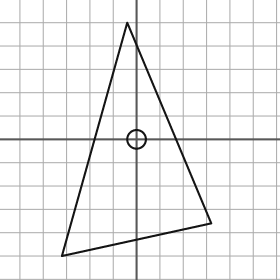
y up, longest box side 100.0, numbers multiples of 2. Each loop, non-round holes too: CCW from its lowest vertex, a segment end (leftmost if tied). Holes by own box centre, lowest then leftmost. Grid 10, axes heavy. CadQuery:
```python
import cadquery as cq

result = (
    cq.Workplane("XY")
    .moveTo(-32.0, -50.0)
    .lineTo(32.0, -36.0)
    .lineTo(-4.0, 50.0)
    .close()
    .moveTo(0.0, 0.0)
    .circle(4.0)
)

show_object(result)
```